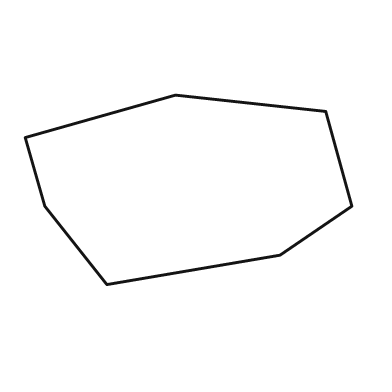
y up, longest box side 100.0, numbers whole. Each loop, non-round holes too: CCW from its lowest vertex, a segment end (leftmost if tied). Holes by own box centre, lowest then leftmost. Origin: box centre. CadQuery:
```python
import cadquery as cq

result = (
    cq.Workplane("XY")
    .moveTo(-25.0, -29.0)
    .lineTo(28.0, -20.0)
    .lineTo(50.0, -5.0)
    .lineTo(42.0, 24.0)
    .lineTo(-4.0, 29.0)
    .lineTo(-50.0, 16.0)
    .lineTo(-44.0, -5.0)
    .close()
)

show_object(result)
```